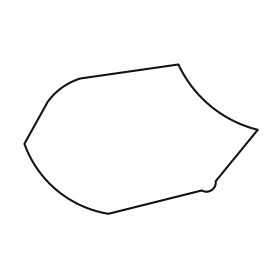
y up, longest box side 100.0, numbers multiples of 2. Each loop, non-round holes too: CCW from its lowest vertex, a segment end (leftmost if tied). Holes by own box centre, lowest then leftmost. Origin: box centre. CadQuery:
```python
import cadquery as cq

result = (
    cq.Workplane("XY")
    .moveTo(-14.0, -32.0)
    .lineTo(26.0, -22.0)
    .threePointArc((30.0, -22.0), (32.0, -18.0))
    .lineTo(50.0, 4.0)
    .threePointArc((30.0, 14.0), (16.0, 32.0))
    .lineTo(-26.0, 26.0)
    .threePointArc((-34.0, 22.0), (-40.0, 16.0))
    .lineTo(-50.0, -2.0)
    .threePointArc((-36.0, -22.0), (-14.0, -32.0))
    .close()
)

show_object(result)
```